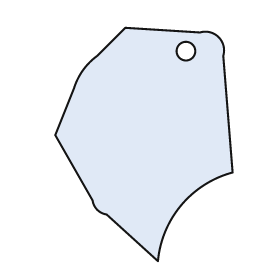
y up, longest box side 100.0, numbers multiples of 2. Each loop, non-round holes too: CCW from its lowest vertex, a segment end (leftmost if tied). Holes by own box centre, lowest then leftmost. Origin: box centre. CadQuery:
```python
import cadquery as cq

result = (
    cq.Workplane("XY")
    .moveTo(6.0, -50.0)
    .threePointArc((16.0, -26.0), (38.0, -12.0))
    .lineTo(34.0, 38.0)
    .threePointArc((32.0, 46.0), (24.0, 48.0))
    .lineTo(-8.0, 50.0)
    .lineTo(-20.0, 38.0)
    .threePointArc((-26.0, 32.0), (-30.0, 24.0))
    .lineTo(-38.0, 4.0)
    .lineTo(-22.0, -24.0)
    .threePointArc((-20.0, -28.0), (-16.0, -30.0))
    .close()
    .moveTo(18.0, 40.0)
    .circle(4.0)
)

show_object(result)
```